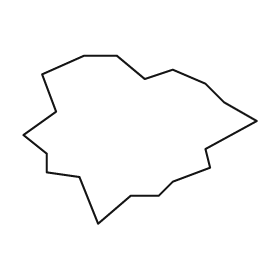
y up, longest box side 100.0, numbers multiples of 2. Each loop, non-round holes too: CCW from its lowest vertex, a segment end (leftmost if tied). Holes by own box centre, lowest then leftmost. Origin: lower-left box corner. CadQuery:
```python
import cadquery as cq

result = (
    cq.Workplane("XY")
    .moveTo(32.0, 0.0)
    .lineTo(46.0, 12.0)
    .lineTo(58.0, 12.0)
    .lineTo(64.0, 18.0)
    .lineTo(80.0, 24.0)
    .lineTo(78.0, 32.0)
    .lineTo(100.0, 44.0)
    .lineTo(86.0, 52.0)
    .lineTo(78.0, 60.0)
    .lineTo(64.0, 66.0)
    .lineTo(52.0, 62.0)
    .lineTo(40.0, 72.0)
    .lineTo(26.0, 72.0)
    .lineTo(8.0, 64.0)
    .lineTo(14.0, 48.0)
    .lineTo(0.0, 38.0)
    .lineTo(10.0, 30.0)
    .lineTo(10.0, 22.0)
    .lineTo(24.0, 20.0)
    .close()
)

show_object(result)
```